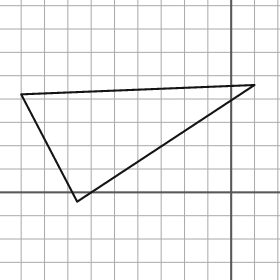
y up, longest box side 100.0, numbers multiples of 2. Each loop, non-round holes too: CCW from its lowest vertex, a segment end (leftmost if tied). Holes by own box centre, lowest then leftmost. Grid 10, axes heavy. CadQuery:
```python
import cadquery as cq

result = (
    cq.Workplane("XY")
    .moveTo(-66.0, -4.0)
    .lineTo(10.0, 46.0)
    .lineTo(-90.0, 42.0)
    .close()
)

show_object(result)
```